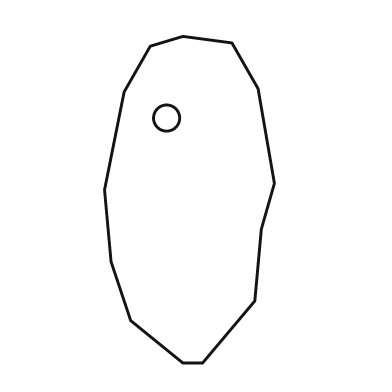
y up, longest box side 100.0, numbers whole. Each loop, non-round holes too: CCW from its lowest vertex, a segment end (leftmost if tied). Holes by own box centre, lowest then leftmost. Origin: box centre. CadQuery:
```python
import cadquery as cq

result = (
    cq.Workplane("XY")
    .moveTo(-2.0, -50.0)
    .lineTo(4.0, -50.0)
    .lineTo(20.0, -31.0)
    .lineTo(22.0, -9.0)
    .lineTo(26.0, 5.0)
    .lineTo(21.0, 34.0)
    .lineTo(13.0, 48.0)
    .lineTo(-2.0, 50.0)
    .lineTo(-12.0, 47.0)
    .lineTo(-20.0, 33.0)
    .lineTo(-26.0, 3.0)
    .lineTo(-24.0, -19.0)
    .lineTo(-18.0, -37.0)
    .close()
    .moveTo(-7.0, 25.0)
    .circle(4.0)
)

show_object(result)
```